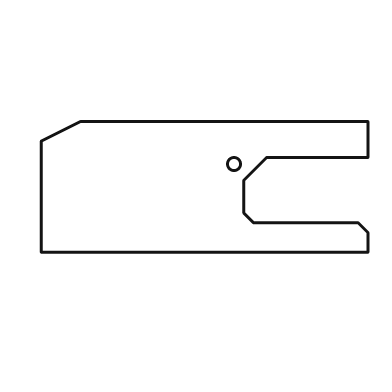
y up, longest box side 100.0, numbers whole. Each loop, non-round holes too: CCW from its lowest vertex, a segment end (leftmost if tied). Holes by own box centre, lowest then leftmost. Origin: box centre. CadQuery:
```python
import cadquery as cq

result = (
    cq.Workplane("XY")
    .moveTo(-50.0, -20.0)
    .lineTo(50.0, -20.0)
    .lineTo(50.0, -14.0)
    .lineTo(47.0, -11.0)
    .lineTo(15.0, -11.0)
    .lineTo(12.0, -8.0)
    .lineTo(12.0, 2.0)
    .lineTo(19.0, 9.0)
    .lineTo(50.0, 9.0)
    .lineTo(50.0, 20.0)
    .lineTo(-38.0, 20.0)
    .lineTo(-50.0, 14.0)
    .close()
    .moveTo(9.0, 7.0)
    .circle(2.0)
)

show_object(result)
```